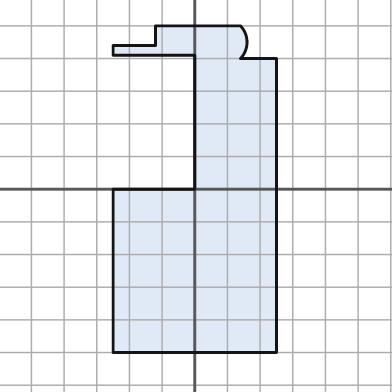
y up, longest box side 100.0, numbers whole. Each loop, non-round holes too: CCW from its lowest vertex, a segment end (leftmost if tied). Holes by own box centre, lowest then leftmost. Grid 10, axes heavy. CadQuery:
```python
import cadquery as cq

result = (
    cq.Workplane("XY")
    .moveTo(-25.0, -50.0)
    .lineTo(25.0, -50.0)
    .lineTo(25.0, 40.0)
    .lineTo(14.0, 40.0)
    .threePointArc((16.0, 45.0), (14.0, 50.0))
    .lineTo(-12.0, 50.0)
    .lineTo(-12.0, 44.0)
    .lineTo(-25.0, 44.0)
    .lineTo(-25.0, 41.0)
    .lineTo(0.0, 41.0)
    .lineTo(0.0, 0.0)
    .lineTo(-25.0, 0.0)
    .close()
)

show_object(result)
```